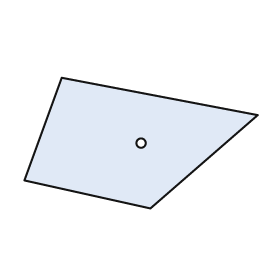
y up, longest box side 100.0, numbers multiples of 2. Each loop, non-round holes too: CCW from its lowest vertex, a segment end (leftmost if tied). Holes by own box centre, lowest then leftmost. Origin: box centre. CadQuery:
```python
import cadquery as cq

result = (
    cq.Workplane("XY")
    .moveTo(4.0, -28.0)
    .lineTo(50.0, 12.0)
    .lineTo(-34.0, 28.0)
    .lineTo(-50.0, -16.0)
    .close()
    .moveTo(0.0, 0.0)
    .circle(2.0)
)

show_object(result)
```